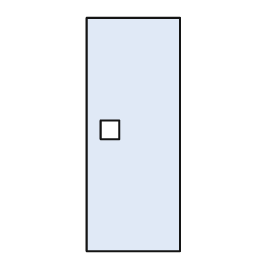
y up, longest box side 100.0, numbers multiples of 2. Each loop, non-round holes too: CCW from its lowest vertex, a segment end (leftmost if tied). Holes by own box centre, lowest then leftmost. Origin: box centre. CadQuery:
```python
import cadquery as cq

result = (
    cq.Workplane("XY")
    .moveTo(-20.0, -50.0)
    .lineTo(20.0, -50.0)
    .lineTo(20.0, 50.0)
    .lineTo(-20.0, 50.0)
    .close()
    .moveTo(-14.0, -2.0)
    .lineTo(-6.0, -2.0)
    .lineTo(-6.0, 6.0)
    .lineTo(-14.0, 6.0)
    .close()
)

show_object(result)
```